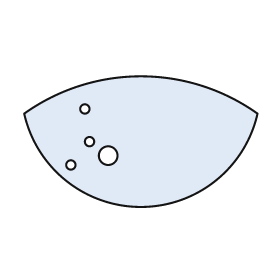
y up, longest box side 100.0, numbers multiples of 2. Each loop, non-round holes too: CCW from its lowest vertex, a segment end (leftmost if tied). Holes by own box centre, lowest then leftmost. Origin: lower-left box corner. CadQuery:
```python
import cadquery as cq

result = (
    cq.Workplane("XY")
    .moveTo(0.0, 40.0)
    .threePointArc((50.0, 0.0), (100.0, 40.0))
    .threePointArc((50.0, 56.0), (0.0, 40.0))
    .close()
    .moveTo(20.0, 18.0)
    .circle(2.0)
    .moveTo(36.0, 22.0)
    .circle(4.0)
    .moveTo(28.0, 28.0)
    .circle(2.0)
    .moveTo(26.0, 42.0)
    .circle(2.0)
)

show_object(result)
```